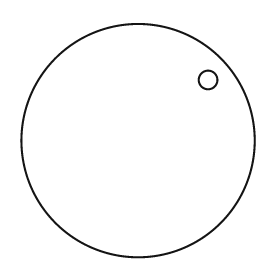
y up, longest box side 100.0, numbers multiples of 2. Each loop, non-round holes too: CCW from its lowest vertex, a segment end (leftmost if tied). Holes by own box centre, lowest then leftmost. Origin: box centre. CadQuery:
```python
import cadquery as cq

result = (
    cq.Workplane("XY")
    .moveTo(0.0, 0.0)
    .circle(50.0)
    .moveTo(30.0, 26.0)
    .circle(4.0)
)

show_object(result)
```